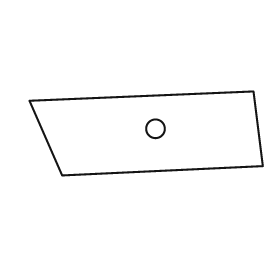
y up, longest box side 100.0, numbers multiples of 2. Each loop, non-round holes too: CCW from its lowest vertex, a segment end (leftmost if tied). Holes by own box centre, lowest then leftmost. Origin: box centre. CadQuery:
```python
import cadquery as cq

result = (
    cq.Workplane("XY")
    .moveTo(-36.0, -18.0)
    .lineTo(50.0, -14.0)
    .lineTo(46.0, 18.0)
    .lineTo(-50.0, 14.0)
    .close()
    .moveTo(4.0, 2.0)
    .circle(4.0)
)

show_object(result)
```